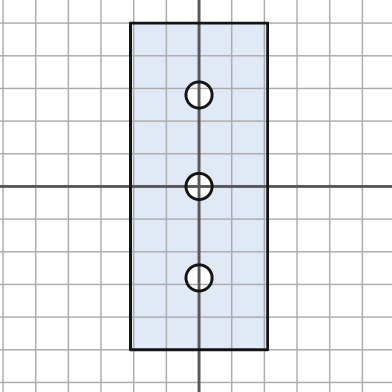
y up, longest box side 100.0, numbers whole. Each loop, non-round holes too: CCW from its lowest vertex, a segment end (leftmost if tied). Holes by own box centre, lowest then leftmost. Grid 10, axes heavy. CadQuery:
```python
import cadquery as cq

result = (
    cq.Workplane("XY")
    .moveTo(-21.0, -50.0)
    .lineTo(21.0, -50.0)
    .lineTo(21.0, 50.0)
    .lineTo(-21.0, 50.0)
    .close()
    .moveTo(0.0, -28.0)
    .circle(4.0)
    .moveTo(0.0, 0.0)
    .circle(4.0)
    .moveTo(0.0, 28.0)
    .circle(4.0)
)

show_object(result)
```